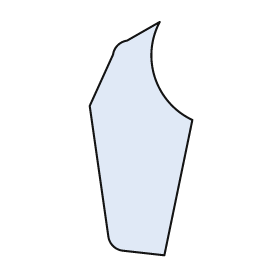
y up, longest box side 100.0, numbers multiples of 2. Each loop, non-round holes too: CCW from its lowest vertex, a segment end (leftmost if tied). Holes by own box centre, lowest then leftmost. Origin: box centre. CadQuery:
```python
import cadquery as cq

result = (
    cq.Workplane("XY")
    .moveTo(10.0, -50.0)
    .lineTo(22.0, 8.0)
    .threePointArc((6.0, 26.0), (8.0, 50.0))
    .lineTo(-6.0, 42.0)
    .threePointArc((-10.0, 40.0), (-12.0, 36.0))
    .lineTo(-22.0, 14.0)
    .lineTo(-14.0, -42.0)
    .threePointArc((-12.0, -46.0), (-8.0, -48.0))
    .close()
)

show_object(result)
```